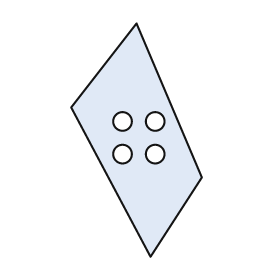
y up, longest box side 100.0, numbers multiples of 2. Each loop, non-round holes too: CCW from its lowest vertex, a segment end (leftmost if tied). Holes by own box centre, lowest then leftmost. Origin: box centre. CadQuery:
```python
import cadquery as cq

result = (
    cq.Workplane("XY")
    .moveTo(6.0, -50.0)
    .lineTo(28.0, -16.0)
    .lineTo(0.0, 50.0)
    .lineTo(-28.0, 14.0)
    .close()
    .moveTo(-6.0, -6.0)
    .circle(4.0)
    .moveTo(8.0, -6.0)
    .circle(4.0)
    .moveTo(-6.0, 8.0)
    .circle(4.0)
    .moveTo(8.0, 8.0)
    .circle(4.0)
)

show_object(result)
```